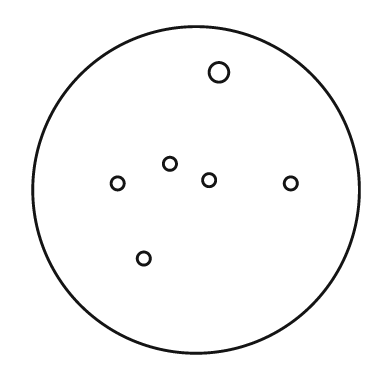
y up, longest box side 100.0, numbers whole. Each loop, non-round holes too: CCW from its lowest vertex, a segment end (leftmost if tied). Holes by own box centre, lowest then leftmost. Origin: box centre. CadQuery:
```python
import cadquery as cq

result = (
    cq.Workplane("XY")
    .moveTo(0.0, 0.0)
    .circle(50.0)
    .moveTo(-16.0, -21.0)
    .circle(2.0)
    .moveTo(-24.0, 2.0)
    .circle(2.0)
    .moveTo(29.0, 2.0)
    .circle(2.0)
    .moveTo(4.0, 3.0)
    .circle(2.0)
    .moveTo(-8.0, 8.0)
    .circle(2.0)
    .moveTo(7.0, 36.0)
    .circle(3.0)
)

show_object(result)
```